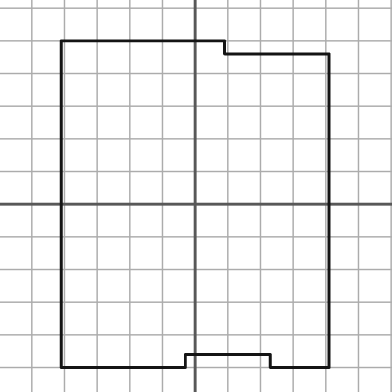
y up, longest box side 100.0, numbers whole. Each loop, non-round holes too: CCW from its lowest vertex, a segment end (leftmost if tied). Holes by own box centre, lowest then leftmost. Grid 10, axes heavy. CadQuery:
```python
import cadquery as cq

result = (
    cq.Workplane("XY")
    .moveTo(-41.0, -50.0)
    .lineTo(-3.0, -50.0)
    .lineTo(-3.0, -46.0)
    .lineTo(23.0, -46.0)
    .lineTo(23.0, -50.0)
    .lineTo(41.0, -50.0)
    .lineTo(41.0, 46.0)
    .lineTo(9.0, 46.0)
    .lineTo(9.0, 50.0)
    .lineTo(-41.0, 50.0)
    .close()
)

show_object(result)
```